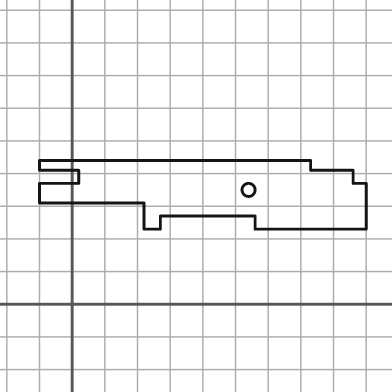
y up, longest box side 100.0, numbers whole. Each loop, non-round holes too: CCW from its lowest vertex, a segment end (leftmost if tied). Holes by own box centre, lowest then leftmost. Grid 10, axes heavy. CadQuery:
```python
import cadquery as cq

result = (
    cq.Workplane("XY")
    .moveTo(22.0, 23.0)
    .lineTo(27.0, 23.0)
    .lineTo(27.0, 27.0)
    .lineTo(56.0, 27.0)
    .lineTo(56.0, 23.0)
    .lineTo(90.0, 23.0)
    .lineTo(90.0, 37.0)
    .lineTo(86.0, 37.0)
    .lineTo(86.0, 41.0)
    .lineTo(73.0, 41.0)
    .lineTo(73.0, 44.0)
    .lineTo(-10.0, 44.0)
    .lineTo(-10.0, 41.0)
    .lineTo(2.0, 41.0)
    .lineTo(2.0, 37.0)
    .lineTo(-10.0, 37.0)
    .lineTo(-10.0, 31.0)
    .lineTo(22.0, 31.0)
    .close()
    .moveTo(54.0, 35.0)
    .circle(2.0)
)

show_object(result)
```